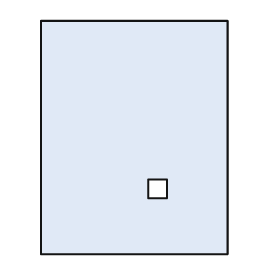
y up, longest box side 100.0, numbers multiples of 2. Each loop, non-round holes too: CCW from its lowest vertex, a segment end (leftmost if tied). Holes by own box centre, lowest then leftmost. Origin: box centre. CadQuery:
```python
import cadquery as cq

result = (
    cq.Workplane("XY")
    .moveTo(-40.0, -50.0)
    .lineTo(40.0, -50.0)
    .lineTo(40.0, 50.0)
    .lineTo(-40.0, 50.0)
    .close()
    .moveTo(6.0, -26.0)
    .lineTo(14.0, -26.0)
    .lineTo(14.0, -18.0)
    .lineTo(6.0, -18.0)
    .close()
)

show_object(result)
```